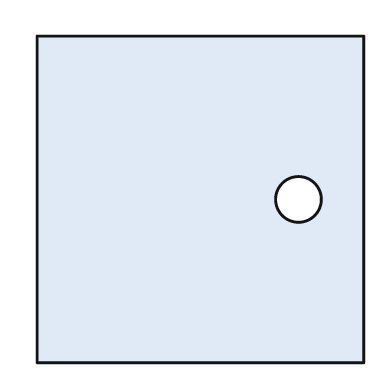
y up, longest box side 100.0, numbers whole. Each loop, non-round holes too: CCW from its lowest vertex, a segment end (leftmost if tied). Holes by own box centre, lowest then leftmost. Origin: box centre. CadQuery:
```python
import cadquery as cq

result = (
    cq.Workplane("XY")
    .moveTo(-50.0, -50.0)
    .lineTo(50.0, -50.0)
    .lineTo(50.0, 50.0)
    .lineTo(-50.0, 50.0)
    .close()
    .moveTo(30.0, 0.0)
    .circle(7.0)
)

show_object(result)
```